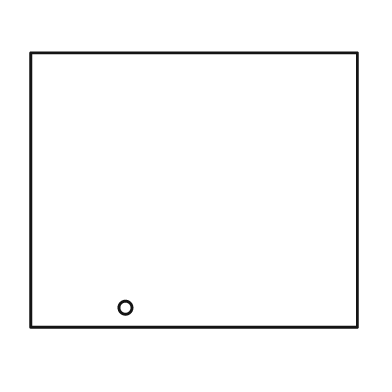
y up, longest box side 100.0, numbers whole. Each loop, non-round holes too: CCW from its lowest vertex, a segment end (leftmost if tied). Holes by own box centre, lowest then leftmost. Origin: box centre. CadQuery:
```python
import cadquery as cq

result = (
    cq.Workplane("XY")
    .moveTo(-50.0, -42.0)
    .lineTo(50.0, -42.0)
    .lineTo(50.0, 42.0)
    .lineTo(-50.0, 42.0)
    .close()
    .moveTo(-21.0, -36.0)
    .circle(2.0)
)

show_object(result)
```